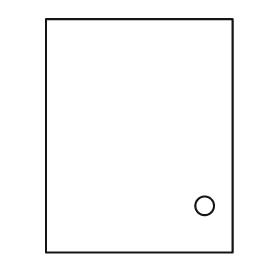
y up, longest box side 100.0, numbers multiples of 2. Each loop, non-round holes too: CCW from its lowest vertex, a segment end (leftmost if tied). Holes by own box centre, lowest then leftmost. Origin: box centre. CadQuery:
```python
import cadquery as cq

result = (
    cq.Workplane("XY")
    .moveTo(-40.0, -50.0)
    .lineTo(40.0, -50.0)
    .lineTo(40.0, 50.0)
    .lineTo(-40.0, 50.0)
    .close()
    .moveTo(28.0, -30.0)
    .circle(4.0)
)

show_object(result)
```